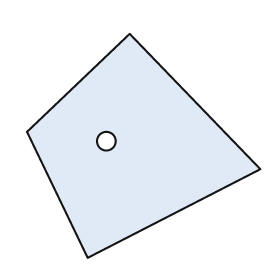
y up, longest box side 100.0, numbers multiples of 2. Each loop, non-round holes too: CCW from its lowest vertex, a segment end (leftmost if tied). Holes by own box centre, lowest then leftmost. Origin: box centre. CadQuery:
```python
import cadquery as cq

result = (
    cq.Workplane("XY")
    .moveTo(-24.0, -48.0)
    .lineTo(50.0, -10.0)
    .lineTo(-6.0, 48.0)
    .lineTo(-50.0, 6.0)
    .close()
    .moveTo(-16.0, 2.0)
    .circle(4.0)
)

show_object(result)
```